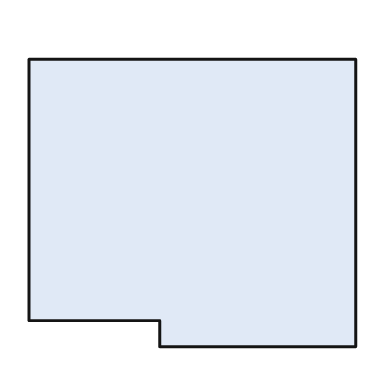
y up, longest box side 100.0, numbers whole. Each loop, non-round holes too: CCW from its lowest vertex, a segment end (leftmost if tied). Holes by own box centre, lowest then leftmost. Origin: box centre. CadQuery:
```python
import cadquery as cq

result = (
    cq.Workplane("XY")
    .moveTo(-10.0, -44.0)
    .lineTo(50.0, -44.0)
    .lineTo(50.0, 44.0)
    .lineTo(-50.0, 44.0)
    .lineTo(-50.0, -36.0)
    .lineTo(-10.0, -36.0)
    .close()
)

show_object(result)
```